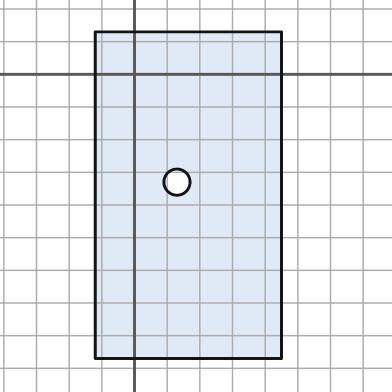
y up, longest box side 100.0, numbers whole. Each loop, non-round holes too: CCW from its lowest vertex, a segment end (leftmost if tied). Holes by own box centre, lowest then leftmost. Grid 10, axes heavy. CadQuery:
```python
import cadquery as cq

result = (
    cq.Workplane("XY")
    .moveTo(-12.0, -87.0)
    .lineTo(45.0, -87.0)
    .lineTo(45.0, 13.0)
    .lineTo(-12.0, 13.0)
    .close()
    .moveTo(13.0, -33.0)
    .circle(4.0)
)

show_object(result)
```